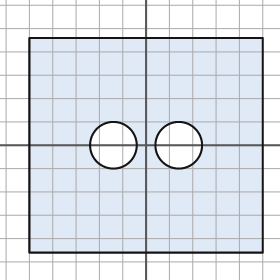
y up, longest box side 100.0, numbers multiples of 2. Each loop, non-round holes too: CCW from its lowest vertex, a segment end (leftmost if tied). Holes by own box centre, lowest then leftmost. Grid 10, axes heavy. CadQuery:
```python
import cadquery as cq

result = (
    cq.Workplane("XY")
    .moveTo(-50.0, -46.0)
    .lineTo(50.0, -46.0)
    .lineTo(50.0, 46.0)
    .lineTo(-50.0, 46.0)
    .close()
    .moveTo(-14.0, 0.0)
    .circle(10.0)
    .moveTo(14.0, 0.0)
    .circle(10.0)
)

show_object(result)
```